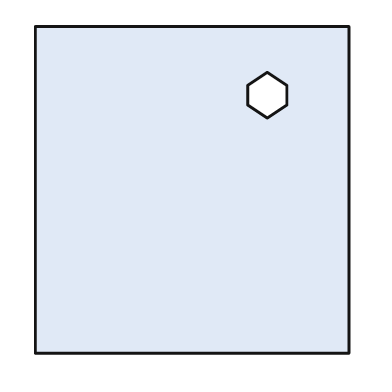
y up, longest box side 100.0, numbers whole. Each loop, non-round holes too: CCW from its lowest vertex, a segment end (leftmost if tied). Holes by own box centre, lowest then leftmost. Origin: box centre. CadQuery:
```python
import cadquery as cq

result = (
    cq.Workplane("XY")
    .moveTo(-48.0, -50.0)
    .lineTo(48.0, -50.0)
    .lineTo(48.0, 50.0)
    .lineTo(-48.0, 50.0)
    .close()
    .moveTo(23.0, 22.0)
    .lineTo(29.0, 26.0)
    .lineTo(29.0, 32.0)
    .lineTo(23.0, 36.0)
    .lineTo(17.0, 32.0)
    .lineTo(17.0, 26.0)
    .close()
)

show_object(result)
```